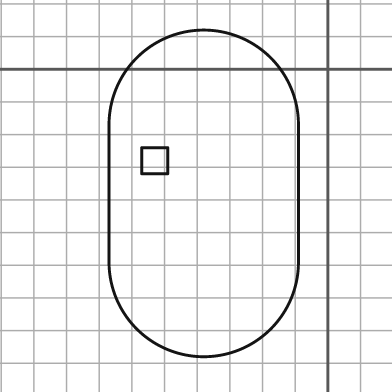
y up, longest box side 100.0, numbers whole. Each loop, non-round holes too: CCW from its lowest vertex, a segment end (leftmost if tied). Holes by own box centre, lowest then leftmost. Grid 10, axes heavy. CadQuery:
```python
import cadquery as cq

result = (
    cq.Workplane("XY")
    .moveTo(-67.0, -59.0)
    .threePointArc((-38.0, -88.0), (-9.0, -59.0))
    .lineTo(-9.0, -17.0)
    .threePointArc((-38.0, 12.0), (-67.0, -17.0))
    .close()
    .moveTo(-57.0, -32.0)
    .lineTo(-49.0, -32.0)
    .lineTo(-49.0, -24.0)
    .lineTo(-57.0, -24.0)
    .close()
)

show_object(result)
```